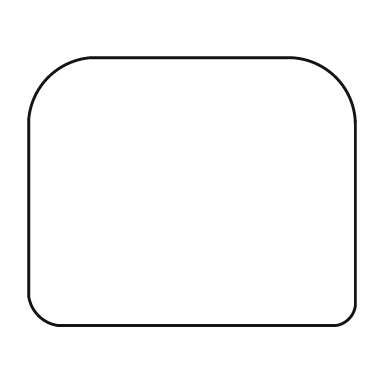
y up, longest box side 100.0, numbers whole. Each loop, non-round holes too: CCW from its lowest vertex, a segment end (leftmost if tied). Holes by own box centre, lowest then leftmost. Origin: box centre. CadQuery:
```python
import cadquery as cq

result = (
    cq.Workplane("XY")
    .moveTo(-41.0, -41.0)
    .lineTo(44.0, -41.0)
    .threePointArc((48.0, -39.0), (50.0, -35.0))
    .lineTo(50.0, 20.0)
    .threePointArc((44.0, 35.0), (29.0, 41.0))
    .lineTo(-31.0, 41.0)
    .threePointArc((-44.0, 35.0), (-50.0, 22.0))
    .lineTo(-50.0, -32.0)
    .threePointArc((-47.0, -38.0), (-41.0, -41.0))
    .close()
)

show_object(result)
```